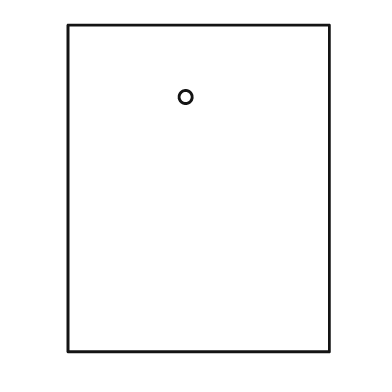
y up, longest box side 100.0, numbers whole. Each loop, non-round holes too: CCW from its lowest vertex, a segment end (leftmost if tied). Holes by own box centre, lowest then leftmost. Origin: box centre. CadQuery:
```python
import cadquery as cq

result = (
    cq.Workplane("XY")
    .moveTo(-40.0, -50.0)
    .lineTo(40.0, -50.0)
    .lineTo(40.0, 50.0)
    .lineTo(-40.0, 50.0)
    .close()
    .moveTo(-4.0, 28.0)
    .circle(2.0)
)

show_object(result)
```